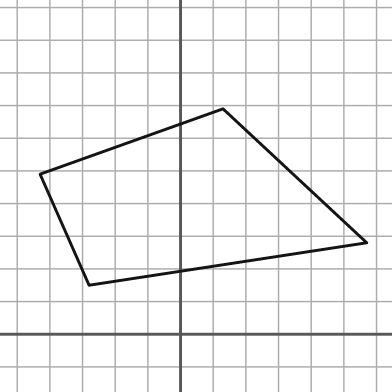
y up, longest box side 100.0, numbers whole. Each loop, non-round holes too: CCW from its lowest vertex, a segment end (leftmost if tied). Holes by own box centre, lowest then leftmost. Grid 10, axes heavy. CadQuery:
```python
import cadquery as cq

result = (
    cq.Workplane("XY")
    .moveTo(-28.0, 15.0)
    .lineTo(57.0, 28.0)
    .lineTo(13.0, 69.0)
    .lineTo(-43.0, 49.0)
    .close()
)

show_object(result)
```